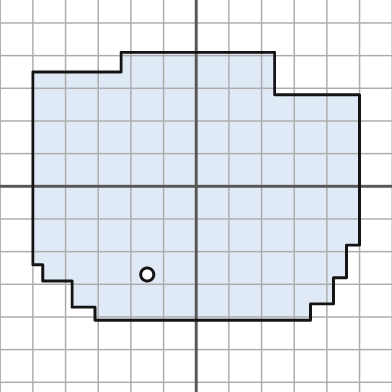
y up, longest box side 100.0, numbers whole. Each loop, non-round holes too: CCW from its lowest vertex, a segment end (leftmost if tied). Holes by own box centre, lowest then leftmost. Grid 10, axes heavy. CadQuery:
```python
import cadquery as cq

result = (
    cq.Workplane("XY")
    .moveTo(-31.0, -41.0)
    .lineTo(35.0, -41.0)
    .lineTo(35.0, -36.0)
    .lineTo(42.0, -36.0)
    .lineTo(42.0, -28.0)
    .lineTo(46.0, -28.0)
    .lineTo(46.0, -18.0)
    .lineTo(50.0, -18.0)
    .lineTo(50.0, 28.0)
    .lineTo(24.0, 28.0)
    .lineTo(24.0, 41.0)
    .lineTo(-23.0, 41.0)
    .lineTo(-23.0, 35.0)
    .lineTo(-50.0, 35.0)
    .lineTo(-50.0, -24.0)
    .lineTo(-47.0, -24.0)
    .lineTo(-47.0, -29.0)
    .lineTo(-38.0, -29.0)
    .lineTo(-38.0, -37.0)
    .lineTo(-31.0, -37.0)
    .close()
    .moveTo(-15.0, -27.0)
    .circle(2.0)
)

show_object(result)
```